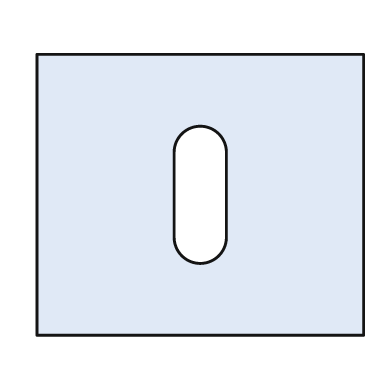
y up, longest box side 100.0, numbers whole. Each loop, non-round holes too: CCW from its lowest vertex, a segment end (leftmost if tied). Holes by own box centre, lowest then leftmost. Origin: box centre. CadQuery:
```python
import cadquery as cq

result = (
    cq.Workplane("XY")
    .moveTo(-50.0, -43.0)
    .lineTo(50.0, -43.0)
    .lineTo(50.0, 43.0)
    .lineTo(-50.0, 43.0)
    .close()
    .moveTo(-8.0, -13.0)
    .threePointArc((0.0, -21.0), (8.0, -13.0))
    .lineTo(8.0, 13.0)
    .threePointArc((0.0, 21.0), (-8.0, 13.0))
    .close()
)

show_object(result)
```